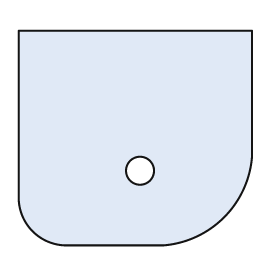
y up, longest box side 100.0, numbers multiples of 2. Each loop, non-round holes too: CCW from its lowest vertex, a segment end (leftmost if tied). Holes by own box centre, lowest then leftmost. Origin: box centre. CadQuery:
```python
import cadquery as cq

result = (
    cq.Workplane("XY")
    .moveTo(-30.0, -46.0)
    .lineTo(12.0, -46.0)
    .threePointArc((38.0, -34.0), (50.0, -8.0))
    .lineTo(50.0, 46.0)
    .lineTo(-50.0, 46.0)
    .lineTo(-50.0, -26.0)
    .threePointArc((-44.0, -40.0), (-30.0, -46.0))
    .close()
    .moveTo(2.0, -14.0)
    .circle(6.0)
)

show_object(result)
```